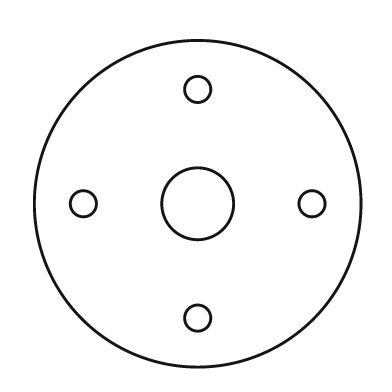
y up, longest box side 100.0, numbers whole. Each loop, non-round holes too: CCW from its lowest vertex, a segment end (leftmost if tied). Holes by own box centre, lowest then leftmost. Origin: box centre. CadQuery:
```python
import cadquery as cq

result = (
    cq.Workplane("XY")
    .moveTo(0.0, 0.0)
    .circle(50.0)
    .moveTo(0.0, -35.0)
    .circle(4.0)
    .moveTo(-35.0, 0.0)
    .circle(4.0)
    .moveTo(0.0, 0.0)
    .circle(11.0)
    .moveTo(35.0, 0.0)
    .circle(4.0)
    .moveTo(0.0, 35.0)
    .circle(4.0)
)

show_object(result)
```